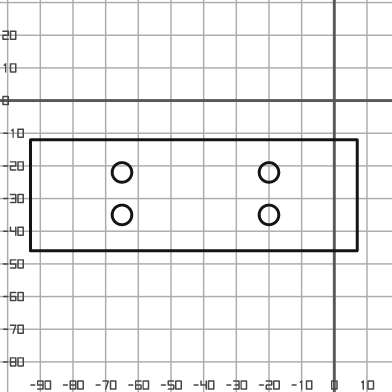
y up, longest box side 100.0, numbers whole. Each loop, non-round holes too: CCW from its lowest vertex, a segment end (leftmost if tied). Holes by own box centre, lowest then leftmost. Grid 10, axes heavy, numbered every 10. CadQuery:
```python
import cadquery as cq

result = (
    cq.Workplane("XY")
    .moveTo(-93.0, -46.0)
    .lineTo(7.0, -46.0)
    .lineTo(7.0, -12.0)
    .lineTo(-93.0, -12.0)
    .close()
    .moveTo(-65.0, -35.0)
    .circle(3.0)
    .moveTo(-20.0, -35.0)
    .circle(3.0)
    .moveTo(-65.0, -22.0)
    .circle(3.0)
    .moveTo(-20.0, -22.0)
    .circle(3.0)
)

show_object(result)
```